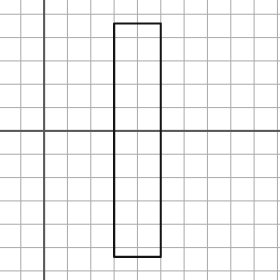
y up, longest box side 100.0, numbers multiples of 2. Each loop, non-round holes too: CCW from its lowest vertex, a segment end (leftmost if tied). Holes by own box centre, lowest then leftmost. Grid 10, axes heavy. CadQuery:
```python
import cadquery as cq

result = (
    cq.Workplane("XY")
    .moveTo(30.0, -54.0)
    .lineTo(50.0, -54.0)
    .lineTo(50.0, 46.0)
    .lineTo(30.0, 46.0)
    .close()
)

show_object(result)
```